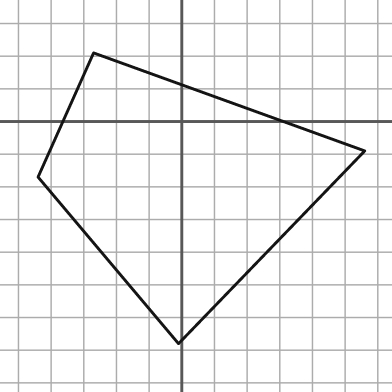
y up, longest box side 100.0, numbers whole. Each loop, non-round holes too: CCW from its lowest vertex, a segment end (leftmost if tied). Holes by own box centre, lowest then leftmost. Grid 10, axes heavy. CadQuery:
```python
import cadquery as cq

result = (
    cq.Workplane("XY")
    .moveTo(-1.0, -68.0)
    .lineTo(56.0, -9.0)
    .lineTo(-27.0, 21.0)
    .lineTo(-44.0, -17.0)
    .close()
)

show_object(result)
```